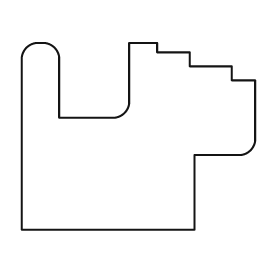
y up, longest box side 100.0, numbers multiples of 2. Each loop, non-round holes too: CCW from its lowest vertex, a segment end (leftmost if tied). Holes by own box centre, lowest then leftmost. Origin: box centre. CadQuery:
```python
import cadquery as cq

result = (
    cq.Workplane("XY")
    .moveTo(-50.0, -40.0)
    .lineTo(24.0, -40.0)
    .lineTo(24.0, -8.0)
    .lineTo(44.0, -8.0)
    .threePointArc((48.0, -6.0), (50.0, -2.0))
    .lineTo(50.0, 24.0)
    .lineTo(40.0, 24.0)
    .lineTo(40.0, 30.0)
    .lineTo(22.0, 30.0)
    .lineTo(22.0, 36.0)
    .lineTo(8.0, 36.0)
    .lineTo(8.0, 40.0)
    .lineTo(-4.0, 40.0)
    .lineTo(-4.0, 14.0)
    .threePointArc((-6.0, 10.0), (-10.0, 8.0))
    .lineTo(-34.0, 8.0)
    .lineTo(-34.0, 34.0)
    .threePointArc((-36.0, 38.0), (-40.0, 40.0))
    .lineTo(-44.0, 40.0)
    .threePointArc((-48.0, 38.0), (-50.0, 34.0))
    .close()
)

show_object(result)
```